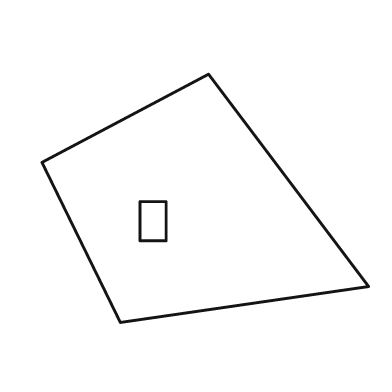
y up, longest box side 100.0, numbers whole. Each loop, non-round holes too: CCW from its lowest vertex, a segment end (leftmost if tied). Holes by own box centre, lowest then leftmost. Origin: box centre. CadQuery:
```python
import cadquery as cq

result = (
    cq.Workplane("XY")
    .moveTo(-26.0, -38.0)
    .lineTo(50.0, -27.0)
    .lineTo(1.0, 38.0)
    .lineTo(-50.0, 11.0)
    .close()
    .moveTo(-20.0, -13.0)
    .lineTo(-12.0, -13.0)
    .lineTo(-12.0, -1.0)
    .lineTo(-20.0, -1.0)
    .close()
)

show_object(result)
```